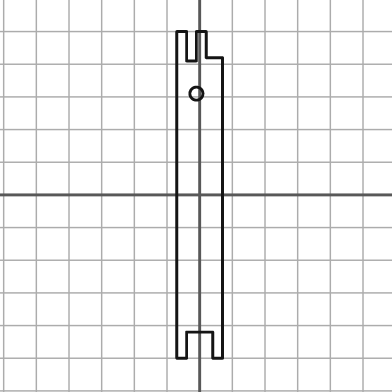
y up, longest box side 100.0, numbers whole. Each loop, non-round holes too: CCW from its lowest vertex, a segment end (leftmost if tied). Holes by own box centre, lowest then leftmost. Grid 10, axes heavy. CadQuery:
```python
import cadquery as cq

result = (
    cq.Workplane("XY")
    .moveTo(-7.0, -50.0)
    .lineTo(-4.0, -50.0)
    .lineTo(-4.0, -42.0)
    .lineTo(4.0, -42.0)
    .lineTo(4.0, -50.0)
    .lineTo(7.0, -50.0)
    .lineTo(7.0, 42.0)
    .lineTo(2.0, 42.0)
    .lineTo(2.0, 50.0)
    .lineTo(-1.0, 50.0)
    .lineTo(-1.0, 41.0)
    .lineTo(-4.0, 41.0)
    .lineTo(-4.0, 50.0)
    .lineTo(-7.0, 50.0)
    .close()
    .moveTo(-1.0, 31.0)
    .circle(2.0)
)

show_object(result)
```